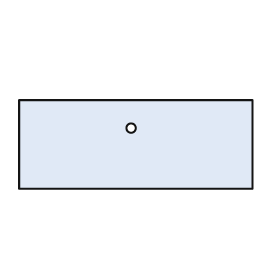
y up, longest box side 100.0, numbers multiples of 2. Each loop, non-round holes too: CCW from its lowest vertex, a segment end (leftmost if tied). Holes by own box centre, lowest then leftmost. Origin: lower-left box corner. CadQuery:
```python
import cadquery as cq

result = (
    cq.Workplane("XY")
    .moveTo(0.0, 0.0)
    .lineTo(100.0, 0.0)
    .lineTo(100.0, 38.0)
    .lineTo(0.0, 38.0)
    .close()
    .moveTo(48.0, 26.0)
    .circle(2.0)
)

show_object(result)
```